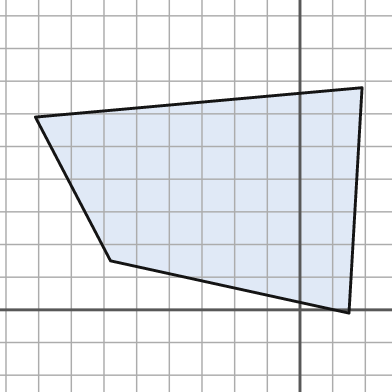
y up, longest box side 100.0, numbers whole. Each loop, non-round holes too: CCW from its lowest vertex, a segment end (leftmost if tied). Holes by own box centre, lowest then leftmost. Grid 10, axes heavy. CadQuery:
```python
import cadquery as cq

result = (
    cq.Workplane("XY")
    .moveTo(15.0, -1.0)
    .lineTo(19.0, 68.0)
    .lineTo(-81.0, 59.0)
    .lineTo(-58.0, 15.0)
    .close()
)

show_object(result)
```